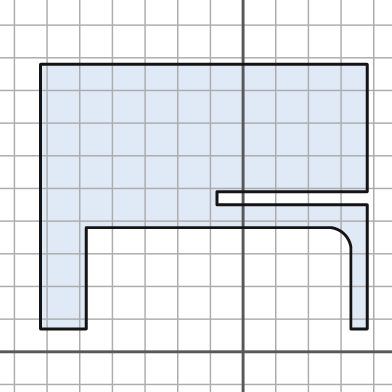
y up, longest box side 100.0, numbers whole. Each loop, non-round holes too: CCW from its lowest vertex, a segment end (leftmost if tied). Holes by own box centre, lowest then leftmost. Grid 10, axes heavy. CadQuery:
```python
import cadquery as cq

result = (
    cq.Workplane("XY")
    .moveTo(-62.0, 7.0)
    .lineTo(-48.0, 7.0)
    .lineTo(-48.0, 38.0)
    .lineTo(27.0, 38.0)
    .threePointArc((31.0, 36.0), (33.0, 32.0))
    .lineTo(33.0, 7.0)
    .lineTo(38.0, 7.0)
    .lineTo(38.0, 45.0)
    .lineTo(-8.0, 45.0)
    .lineTo(-8.0, 49.0)
    .lineTo(38.0, 49.0)
    .lineTo(38.0, 88.0)
    .lineTo(-62.0, 88.0)
    .close()
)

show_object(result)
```